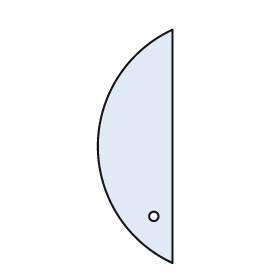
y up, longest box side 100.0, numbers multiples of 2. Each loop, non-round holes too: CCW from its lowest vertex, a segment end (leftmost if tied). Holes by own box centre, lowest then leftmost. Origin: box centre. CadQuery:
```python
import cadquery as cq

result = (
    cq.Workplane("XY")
    .moveTo(16.0, -50.0)
    .lineTo(16.0, 50.0)
    .threePointArc((-16.0, 0.0), (16.0, -50.0))
    .close()
    .moveTo(8.0, -30.0)
    .circle(2.0)
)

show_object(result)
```